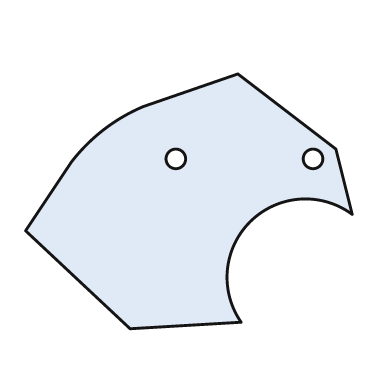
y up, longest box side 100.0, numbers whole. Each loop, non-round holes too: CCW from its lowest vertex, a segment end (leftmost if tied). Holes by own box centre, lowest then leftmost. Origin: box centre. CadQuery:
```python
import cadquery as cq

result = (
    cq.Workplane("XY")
    .moveTo(-18.0, -39.0)
    .lineTo(16.0, -37.0)
    .threePointArc((19.0, -6.0), (50.0, -4.0))
    .lineTo(45.0, 16.0)
    .lineTo(15.0, 39.0)
    .lineTo(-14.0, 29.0)
    .threePointArc((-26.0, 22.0), (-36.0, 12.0))
    .lineTo(-50.0, -9.0)
    .close()
    .moveTo(-4.0, 13.0)
    .circle(3.0)
    .moveTo(38.0, 13.0)
    .circle(3.0)
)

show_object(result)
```